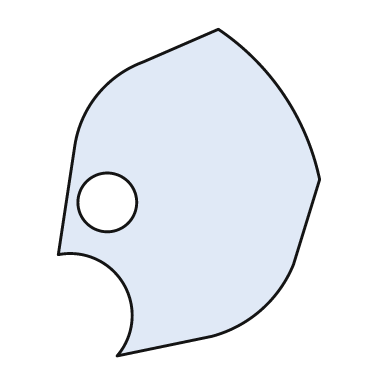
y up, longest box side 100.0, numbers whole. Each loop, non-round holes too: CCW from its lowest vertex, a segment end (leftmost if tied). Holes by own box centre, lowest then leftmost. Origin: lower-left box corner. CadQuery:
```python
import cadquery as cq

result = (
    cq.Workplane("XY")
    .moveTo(18.0, 0.0)
    .lineTo(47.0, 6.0)
    .threePointArc((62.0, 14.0), (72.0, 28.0))
    .lineTo(80.0, 54.0)
    .threePointArc((69.0, 80.0), (49.0, 100.0))
    .lineTo(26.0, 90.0)
    .threePointArc((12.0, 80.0), (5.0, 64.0))
    .lineTo(0.0, 31.0)
    .threePointArc((20.0, 22.0), (18.0, 0.0))
    .close()
    .moveTo(15.0, 47.0)
    .circle(9.0)
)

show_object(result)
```